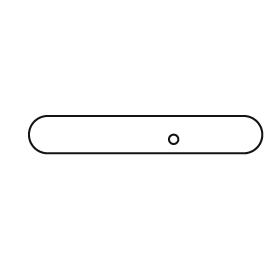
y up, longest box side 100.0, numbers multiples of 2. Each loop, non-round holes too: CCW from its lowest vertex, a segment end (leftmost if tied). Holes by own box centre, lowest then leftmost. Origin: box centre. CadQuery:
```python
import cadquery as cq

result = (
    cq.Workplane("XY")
    .moveTo(-42.0, -8.0)
    .lineTo(42.0, -8.0)
    .threePointArc((50.0, 0.0), (42.0, 8.0))
    .lineTo(-42.0, 8.0)
    .threePointArc((-50.0, 0.0), (-42.0, -8.0))
    .close()
    .moveTo(12.0, -2.0)
    .circle(2.0)
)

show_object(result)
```